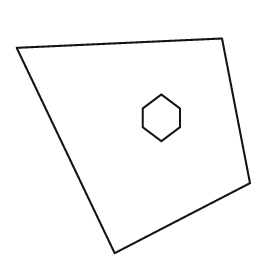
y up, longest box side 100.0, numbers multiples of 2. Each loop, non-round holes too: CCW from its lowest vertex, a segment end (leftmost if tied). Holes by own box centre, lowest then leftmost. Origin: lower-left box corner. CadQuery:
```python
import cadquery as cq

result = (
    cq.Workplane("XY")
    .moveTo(42.0, 0.0)
    .lineTo(100.0, 30.0)
    .lineTo(88.0, 92.0)
    .lineTo(0.0, 88.0)
    .close()
    .moveTo(62.0, 48.0)
    .lineTo(70.0, 54.0)
    .lineTo(70.0, 62.0)
    .lineTo(62.0, 68.0)
    .lineTo(54.0, 62.0)
    .lineTo(54.0, 54.0)
    .close()
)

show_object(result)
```